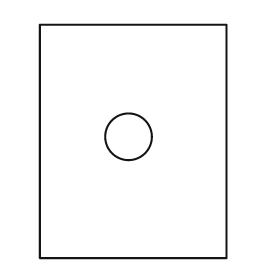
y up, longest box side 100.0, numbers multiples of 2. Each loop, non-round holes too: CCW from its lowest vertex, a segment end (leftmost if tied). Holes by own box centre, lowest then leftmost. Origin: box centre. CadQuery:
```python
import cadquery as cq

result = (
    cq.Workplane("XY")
    .moveTo(-40.0, -50.0)
    .lineTo(40.0, -50.0)
    .lineTo(40.0, 50.0)
    .lineTo(-40.0, 50.0)
    .close()
    .moveTo(-2.0, 2.0)
    .circle(10.0)
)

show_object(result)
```